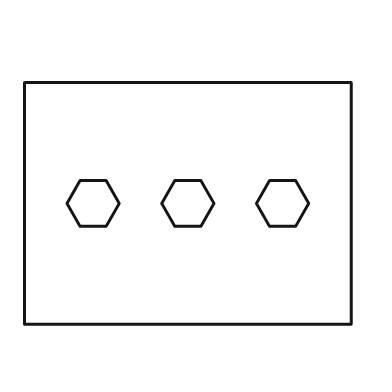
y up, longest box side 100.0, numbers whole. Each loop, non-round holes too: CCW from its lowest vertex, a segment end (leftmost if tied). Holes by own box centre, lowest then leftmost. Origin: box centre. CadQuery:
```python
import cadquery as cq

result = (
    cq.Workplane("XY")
    .moveTo(-50.0, -37.0)
    .lineTo(50.0, -37.0)
    .lineTo(50.0, 37.0)
    .lineTo(-50.0, 37.0)
    .close()
    .moveTo(-33.0, -7.0)
    .lineTo(-25.0, -7.0)
    .lineTo(-21.0, 0.0)
    .lineTo(-25.0, 7.0)
    .lineTo(-33.0, 7.0)
    .lineTo(-37.0, 0.0)
    .close()
    .moveTo(-4.0, -7.0)
    .lineTo(4.0, -7.0)
    .lineTo(8.0, 0.0)
    .lineTo(4.0, 7.0)
    .lineTo(-4.0, 7.0)
    .lineTo(-8.0, 0.0)
    .close()
    .moveTo(25.0, -7.0)
    .lineTo(33.0, -7.0)
    .lineTo(37.0, 0.0)
    .lineTo(33.0, 7.0)
    .lineTo(25.0, 7.0)
    .lineTo(21.0, 0.0)
    .close()
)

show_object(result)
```